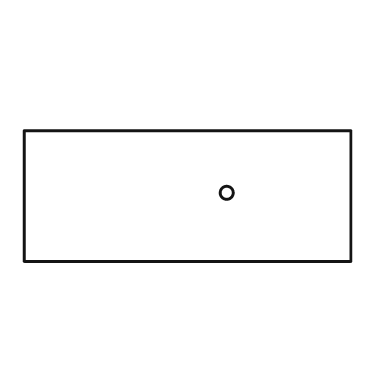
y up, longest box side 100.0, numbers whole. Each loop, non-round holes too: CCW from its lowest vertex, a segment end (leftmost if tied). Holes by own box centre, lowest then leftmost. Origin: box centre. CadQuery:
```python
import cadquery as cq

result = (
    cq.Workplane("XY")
    .moveTo(-50.0, -20.0)
    .lineTo(50.0, -20.0)
    .lineTo(50.0, 20.0)
    .lineTo(-50.0, 20.0)
    .close()
    .moveTo(12.0, 1.0)
    .circle(2.0)
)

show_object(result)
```